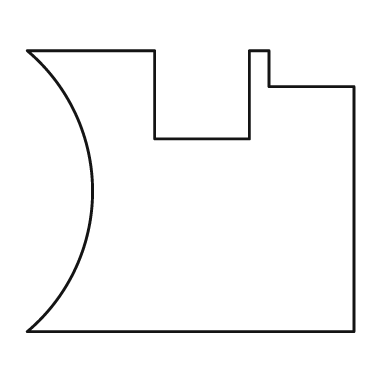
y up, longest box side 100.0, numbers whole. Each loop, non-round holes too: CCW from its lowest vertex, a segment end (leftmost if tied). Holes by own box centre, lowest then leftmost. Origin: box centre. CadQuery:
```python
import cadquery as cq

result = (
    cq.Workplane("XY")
    .moveTo(-50.0, -43.0)
    .lineTo(50.0, -43.0)
    .lineTo(50.0, 32.0)
    .lineTo(24.0, 32.0)
    .lineTo(24.0, 43.0)
    .lineTo(18.0, 43.0)
    .lineTo(18.0, 16.0)
    .lineTo(-11.0, 16.0)
    .lineTo(-11.0, 43.0)
    .lineTo(-50.0, 43.0)
    .threePointArc((-30.0, 0.0), (-50.0, -43.0))
    .close()
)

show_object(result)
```